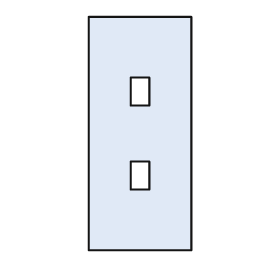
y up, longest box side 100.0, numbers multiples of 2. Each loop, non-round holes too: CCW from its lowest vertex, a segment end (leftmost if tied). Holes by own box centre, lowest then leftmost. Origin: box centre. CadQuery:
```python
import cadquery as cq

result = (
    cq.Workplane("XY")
    .moveTo(-22.0, -50.0)
    .lineTo(22.0, -50.0)
    .lineTo(22.0, 50.0)
    .lineTo(-22.0, 50.0)
    .close()
    .moveTo(-4.0, -24.0)
    .lineTo(4.0, -24.0)
    .lineTo(4.0, -12.0)
    .lineTo(-4.0, -12.0)
    .close()
    .moveTo(-4.0, 12.0)
    .lineTo(4.0, 12.0)
    .lineTo(4.0, 24.0)
    .lineTo(-4.0, 24.0)
    .close()
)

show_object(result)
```